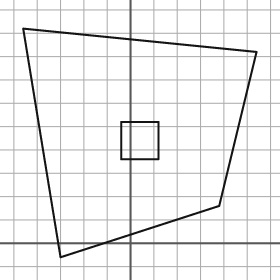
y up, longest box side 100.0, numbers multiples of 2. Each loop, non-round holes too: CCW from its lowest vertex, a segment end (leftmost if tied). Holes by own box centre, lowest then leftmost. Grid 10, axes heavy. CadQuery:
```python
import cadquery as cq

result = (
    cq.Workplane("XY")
    .moveTo(-30.0, -6.0)
    .lineTo(38.0, 16.0)
    .lineTo(54.0, 82.0)
    .lineTo(-46.0, 92.0)
    .close()
    .moveTo(-4.0, 36.0)
    .lineTo(12.0, 36.0)
    .lineTo(12.0, 52.0)
    .lineTo(-4.0, 52.0)
    .close()
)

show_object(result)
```